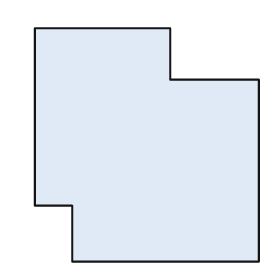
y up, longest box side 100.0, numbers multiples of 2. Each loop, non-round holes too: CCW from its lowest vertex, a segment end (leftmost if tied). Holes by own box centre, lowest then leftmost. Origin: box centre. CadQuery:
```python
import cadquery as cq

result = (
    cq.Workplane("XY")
    .moveTo(-32.0, -50.0)
    .lineTo(48.0, -50.0)
    .lineTo(48.0, 28.0)
    .lineTo(10.0, 28.0)
    .lineTo(10.0, 50.0)
    .lineTo(-48.0, 50.0)
    .lineTo(-48.0, -26.0)
    .lineTo(-32.0, -26.0)
    .close()
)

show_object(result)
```